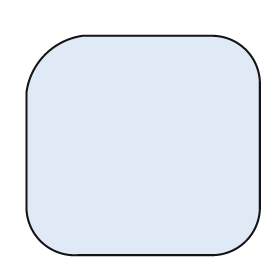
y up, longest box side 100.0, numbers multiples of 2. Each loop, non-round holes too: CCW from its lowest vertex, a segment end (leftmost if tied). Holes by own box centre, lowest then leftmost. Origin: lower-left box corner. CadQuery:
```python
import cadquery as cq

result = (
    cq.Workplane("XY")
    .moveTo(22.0, 0.0)
    .lineTo(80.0, 0.0)
    .threePointArc((94.0, 6.0), (100.0, 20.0))
    .lineTo(100.0, 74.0)
    .threePointArc((94.0, 88.0), (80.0, 94.0))
    .lineTo(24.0, 94.0)
    .threePointArc((8.0, 86.0), (0.0, 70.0))
    .lineTo(0.0, 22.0)
    .threePointArc((6.0, 6.0), (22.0, 0.0))
    .close()
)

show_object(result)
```